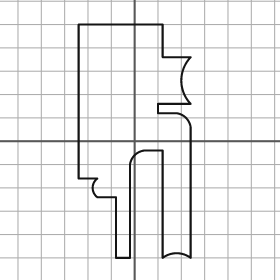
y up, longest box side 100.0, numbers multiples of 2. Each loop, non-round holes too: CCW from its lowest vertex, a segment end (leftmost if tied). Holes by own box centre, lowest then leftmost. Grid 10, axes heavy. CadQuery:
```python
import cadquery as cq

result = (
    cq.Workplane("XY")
    .moveTo(-8.0, -50.0)
    .lineTo(-2.0, -50.0)
    .lineTo(-2.0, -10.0)
    .threePointArc((0.0, -6.0), (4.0, -4.0))
    .lineTo(12.0, -4.0)
    .lineTo(12.0, -50.0)
    .threePointArc((18.0, -48.0), (24.0, -50.0))
    .lineTo(24.0, 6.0)
    .threePointArc((22.0, 10.0), (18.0, 12.0))
    .lineTo(10.0, 12.0)
    .lineTo(10.0, 16.0)
    .lineTo(24.0, 16.0)
    .threePointArc((20.0, 26.0), (24.0, 36.0))
    .lineTo(12.0, 36.0)
    .lineTo(12.0, 50.0)
    .lineTo(-24.0, 50.0)
    .lineTo(-24.0, -16.0)
    .lineTo(-16.0, -16.0)
    .threePointArc((-18.0, -20.0), (-16.0, -24.0))
    .lineTo(-8.0, -24.0)
    .close()
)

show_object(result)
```